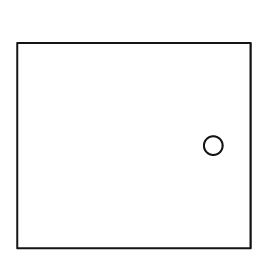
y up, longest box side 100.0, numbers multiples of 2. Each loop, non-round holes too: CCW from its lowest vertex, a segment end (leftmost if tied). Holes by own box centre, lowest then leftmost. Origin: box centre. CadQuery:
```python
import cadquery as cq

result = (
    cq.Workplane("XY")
    .moveTo(-50.0, -44.0)
    .lineTo(50.0, -44.0)
    .lineTo(50.0, 44.0)
    .lineTo(-50.0, 44.0)
    .close()
    .moveTo(34.0, 0.0)
    .circle(4.0)
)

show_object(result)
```